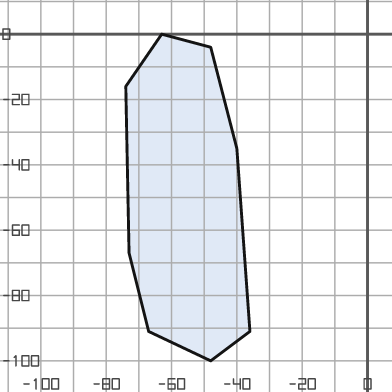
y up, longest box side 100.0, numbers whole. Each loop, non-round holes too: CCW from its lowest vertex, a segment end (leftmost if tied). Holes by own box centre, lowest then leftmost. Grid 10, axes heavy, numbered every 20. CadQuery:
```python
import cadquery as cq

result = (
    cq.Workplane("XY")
    .moveTo(-48.0, -100.0)
    .lineTo(-36.0, -91.0)
    .lineTo(-40.0, -35.0)
    .lineTo(-48.0, -4.0)
    .lineTo(-63.0, 0.0)
    .lineTo(-74.0, -16.0)
    .lineTo(-73.0, -67.0)
    .lineTo(-67.0, -91.0)
    .close()
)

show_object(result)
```